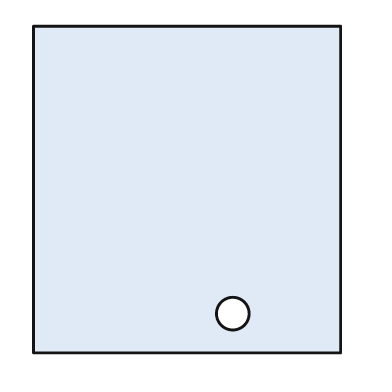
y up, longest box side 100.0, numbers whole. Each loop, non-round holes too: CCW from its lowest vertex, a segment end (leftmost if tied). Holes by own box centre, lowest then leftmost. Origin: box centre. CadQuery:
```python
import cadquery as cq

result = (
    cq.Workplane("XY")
    .moveTo(-47.0, -50.0)
    .lineTo(47.0, -50.0)
    .lineTo(47.0, 50.0)
    .lineTo(-47.0, 50.0)
    .close()
    .moveTo(14.0, -38.0)
    .circle(5.0)
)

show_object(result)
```